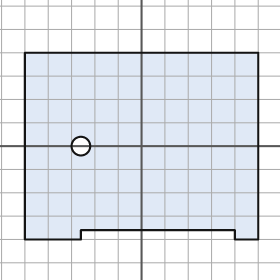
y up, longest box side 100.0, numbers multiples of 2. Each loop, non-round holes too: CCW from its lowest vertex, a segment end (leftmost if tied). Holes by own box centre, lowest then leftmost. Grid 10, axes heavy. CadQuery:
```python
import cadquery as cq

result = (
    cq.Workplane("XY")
    .moveTo(-50.0, -40.0)
    .lineTo(-26.0, -40.0)
    .lineTo(-26.0, -36.0)
    .lineTo(40.0, -36.0)
    .lineTo(40.0, -40.0)
    .lineTo(50.0, -40.0)
    .lineTo(50.0, 40.0)
    .lineTo(-50.0, 40.0)
    .close()
    .moveTo(-26.0, 0.0)
    .circle(4.0)
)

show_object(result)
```